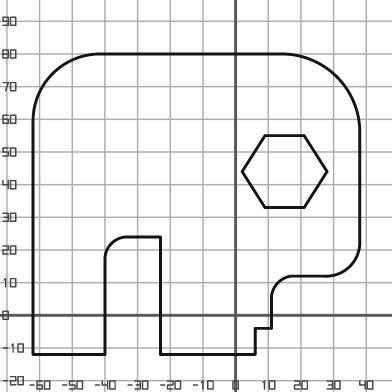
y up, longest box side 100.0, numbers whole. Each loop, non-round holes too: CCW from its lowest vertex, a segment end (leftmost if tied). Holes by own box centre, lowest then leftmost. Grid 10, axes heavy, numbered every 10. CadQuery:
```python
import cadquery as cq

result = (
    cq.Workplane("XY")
    .moveTo(-62.0, -12.0)
    .lineTo(-40.0, -12.0)
    .lineTo(-40.0, 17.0)
    .threePointArc((-38.0, 22.0), (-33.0, 24.0))
    .lineTo(-23.0, 24.0)
    .lineTo(-23.0, -12.0)
    .lineTo(6.0, -12.0)
    .lineTo(6.0, -4.0)
    .lineTo(11.0, -4.0)
    .lineTo(11.0, 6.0)
    .threePointArc((13.0, 10.0), (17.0, 12.0))
    .lineTo(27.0, 12.0)
    .threePointArc((35.0, 15.0), (38.0, 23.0))
    .lineTo(38.0, 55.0)
    .threePointArc((31.0, 73.0), (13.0, 80.0))
    .lineTo(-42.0, 80.0)
    .threePointArc((-56.0, 74.0), (-62.0, 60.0))
    .close()
    .moveTo(9.0, 33.0)
    .lineTo(21.0, 33.0)
    .lineTo(28.0, 44.0)
    .lineTo(21.0, 55.0)
    .lineTo(9.0, 55.0)
    .lineTo(2.0, 44.0)
    .close()
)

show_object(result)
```